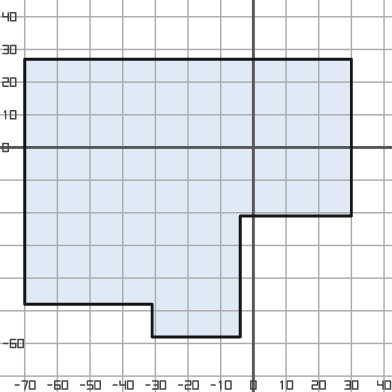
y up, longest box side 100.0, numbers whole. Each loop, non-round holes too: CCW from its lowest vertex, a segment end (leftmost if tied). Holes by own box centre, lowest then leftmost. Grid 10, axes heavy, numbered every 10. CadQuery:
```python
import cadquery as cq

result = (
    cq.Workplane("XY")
    .moveTo(-31.0, -58.0)
    .lineTo(-4.0, -58.0)
    .lineTo(-4.0, -21.0)
    .lineTo(30.0, -21.0)
    .lineTo(30.0, 27.0)
    .lineTo(-70.0, 27.0)
    .lineTo(-70.0, -48.0)
    .lineTo(-31.0, -48.0)
    .close()
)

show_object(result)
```